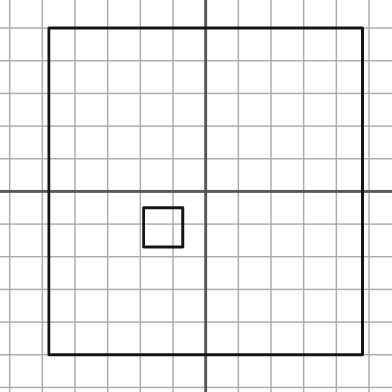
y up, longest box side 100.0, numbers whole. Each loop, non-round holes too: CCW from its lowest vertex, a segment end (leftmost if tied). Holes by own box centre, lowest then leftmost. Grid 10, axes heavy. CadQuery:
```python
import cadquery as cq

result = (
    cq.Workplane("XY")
    .moveTo(-48.0, -50.0)
    .lineTo(48.0, -50.0)
    .lineTo(48.0, 50.0)
    .lineTo(-48.0, 50.0)
    .close()
    .moveTo(-19.0, -17.0)
    .lineTo(-7.0, -17.0)
    .lineTo(-7.0, -5.0)
    .lineTo(-19.0, -5.0)
    .close()
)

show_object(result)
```